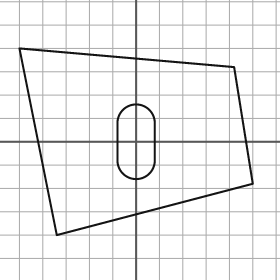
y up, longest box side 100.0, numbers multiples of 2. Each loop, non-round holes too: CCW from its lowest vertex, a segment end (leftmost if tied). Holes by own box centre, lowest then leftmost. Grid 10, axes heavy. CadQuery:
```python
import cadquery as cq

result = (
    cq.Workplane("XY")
    .moveTo(-34.0, -40.0)
    .lineTo(50.0, -18.0)
    .lineTo(42.0, 32.0)
    .lineTo(-50.0, 40.0)
    .close()
    .moveTo(-8.0, -8.0)
    .threePointArc((0.0, -16.0), (8.0, -8.0))
    .lineTo(8.0, 8.0)
    .threePointArc((0.0, 16.0), (-8.0, 8.0))
    .close()
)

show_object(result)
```